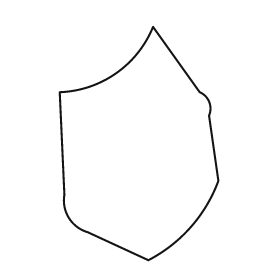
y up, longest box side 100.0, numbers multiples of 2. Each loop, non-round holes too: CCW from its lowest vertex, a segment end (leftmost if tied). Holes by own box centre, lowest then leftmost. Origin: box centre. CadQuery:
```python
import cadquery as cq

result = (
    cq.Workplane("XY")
    .moveTo(4.0, -50.0)
    .threePointArc((22.0, -36.0), (34.0, -16.0))
    .lineTo(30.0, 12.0)
    .threePointArc((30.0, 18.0), (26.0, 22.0))
    .lineTo(6.0, 50.0)
    .threePointArc((-10.0, 30.0), (-34.0, 22.0))
    .lineTo(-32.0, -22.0)
    .threePointArc((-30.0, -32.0), (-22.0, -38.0))
    .close()
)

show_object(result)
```